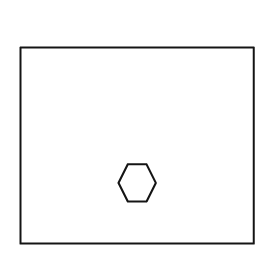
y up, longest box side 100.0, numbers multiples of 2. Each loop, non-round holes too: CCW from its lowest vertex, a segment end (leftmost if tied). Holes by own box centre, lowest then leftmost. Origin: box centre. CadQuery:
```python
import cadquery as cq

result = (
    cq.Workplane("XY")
    .moveTo(-50.0, -42.0)
    .lineTo(50.0, -42.0)
    .lineTo(50.0, 42.0)
    .lineTo(-50.0, 42.0)
    .close()
    .moveTo(-4.0, -24.0)
    .lineTo(4.0, -24.0)
    .lineTo(8.0, -16.0)
    .lineTo(4.0, -8.0)
    .lineTo(-4.0, -8.0)
    .lineTo(-8.0, -16.0)
    .close()
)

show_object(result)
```